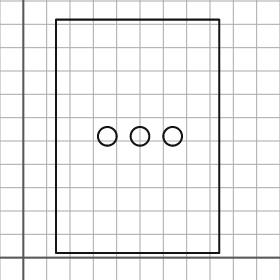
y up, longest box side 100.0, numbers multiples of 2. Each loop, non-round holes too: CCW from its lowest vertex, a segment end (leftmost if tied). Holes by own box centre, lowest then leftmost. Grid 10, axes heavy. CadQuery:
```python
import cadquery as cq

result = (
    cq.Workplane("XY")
    .moveTo(14.0, 2.0)
    .lineTo(84.0, 2.0)
    .lineTo(84.0, 102.0)
    .lineTo(14.0, 102.0)
    .close()
    .moveTo(36.0, 52.0)
    .circle(4.0)
    .moveTo(50.0, 52.0)
    .circle(4.0)
    .moveTo(64.0, 52.0)
    .circle(4.0)
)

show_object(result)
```